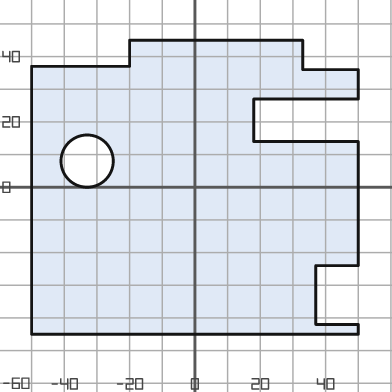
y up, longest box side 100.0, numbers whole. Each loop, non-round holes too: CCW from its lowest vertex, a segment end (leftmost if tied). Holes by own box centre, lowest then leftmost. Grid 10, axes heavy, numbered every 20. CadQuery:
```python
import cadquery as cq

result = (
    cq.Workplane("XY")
    .moveTo(-50.0, -45.0)
    .lineTo(50.0, -45.0)
    .lineTo(50.0, -42.0)
    .lineTo(37.0, -42.0)
    .lineTo(37.0, -24.0)
    .lineTo(50.0, -24.0)
    .lineTo(50.0, 14.0)
    .lineTo(18.0, 14.0)
    .lineTo(18.0, 27.0)
    .lineTo(50.0, 27.0)
    .lineTo(50.0, 36.0)
    .lineTo(33.0, 36.0)
    .lineTo(33.0, 45.0)
    .lineTo(-20.0, 45.0)
    .lineTo(-20.0, 37.0)
    .lineTo(-50.0, 37.0)
    .close()
    .moveTo(-33.0, 8.0)
    .circle(8.0)
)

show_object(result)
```